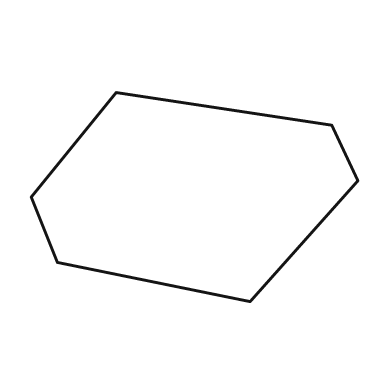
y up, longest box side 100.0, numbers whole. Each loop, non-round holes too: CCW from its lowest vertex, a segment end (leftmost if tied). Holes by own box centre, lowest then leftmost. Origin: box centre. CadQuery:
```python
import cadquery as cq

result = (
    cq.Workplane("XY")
    .moveTo(17.0, -32.0)
    .lineTo(50.0, 5.0)
    .lineTo(42.0, 22.0)
    .lineTo(-24.0, 32.0)
    .lineTo(-50.0, 0.0)
    .lineTo(-42.0, -20.0)
    .close()
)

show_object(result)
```